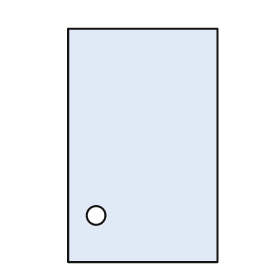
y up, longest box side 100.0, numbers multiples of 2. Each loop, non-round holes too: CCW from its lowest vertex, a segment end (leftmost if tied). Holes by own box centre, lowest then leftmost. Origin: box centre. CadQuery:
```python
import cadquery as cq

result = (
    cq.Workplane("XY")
    .moveTo(-32.0, -50.0)
    .lineTo(32.0, -50.0)
    .lineTo(32.0, 50.0)
    .lineTo(-32.0, 50.0)
    .close()
    .moveTo(-20.0, -30.0)
    .circle(4.0)
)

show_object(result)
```